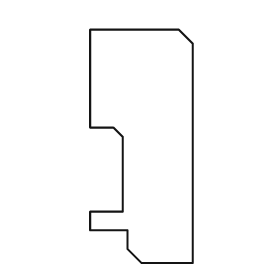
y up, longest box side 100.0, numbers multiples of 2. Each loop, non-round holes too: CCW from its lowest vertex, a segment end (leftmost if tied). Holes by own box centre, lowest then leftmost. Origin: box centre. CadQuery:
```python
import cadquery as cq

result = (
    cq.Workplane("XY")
    .moveTo(0.0, -50.0)
    .lineTo(22.0, -50.0)
    .lineTo(22.0, 44.0)
    .lineTo(16.0, 50.0)
    .lineTo(-22.0, 50.0)
    .lineTo(-22.0, 8.0)
    .lineTo(-12.0, 8.0)
    .lineTo(-8.0, 4.0)
    .lineTo(-8.0, -28.0)
    .lineTo(-22.0, -28.0)
    .lineTo(-22.0, -36.0)
    .lineTo(-6.0, -36.0)
    .lineTo(-6.0, -44.0)
    .close()
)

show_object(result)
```